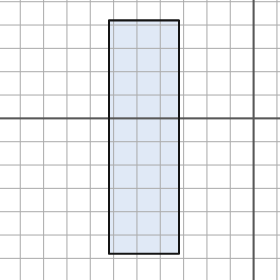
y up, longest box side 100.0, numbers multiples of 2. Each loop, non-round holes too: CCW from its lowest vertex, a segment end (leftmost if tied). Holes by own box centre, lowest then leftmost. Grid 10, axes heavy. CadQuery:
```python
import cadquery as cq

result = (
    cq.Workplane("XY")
    .moveTo(-62.0, -58.0)
    .lineTo(-32.0, -58.0)
    .lineTo(-32.0, 42.0)
    .lineTo(-62.0, 42.0)
    .close()
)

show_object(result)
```